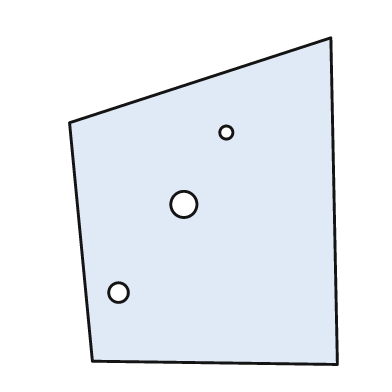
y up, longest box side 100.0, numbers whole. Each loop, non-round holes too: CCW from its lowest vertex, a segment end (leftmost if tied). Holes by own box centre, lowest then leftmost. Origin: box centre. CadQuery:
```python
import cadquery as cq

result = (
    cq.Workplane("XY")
    .moveTo(41.0, -50.0)
    .lineTo(39.0, 50.0)
    .lineTo(-41.0, 24.0)
    .lineTo(-34.0, -49.0)
    .close()
    .moveTo(-26.0, -28.0)
    .circle(3.0)
    .moveTo(-6.0, -1.0)
    .circle(4.0)
    .moveTo(7.0, 21.0)
    .circle(2.0)
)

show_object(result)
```